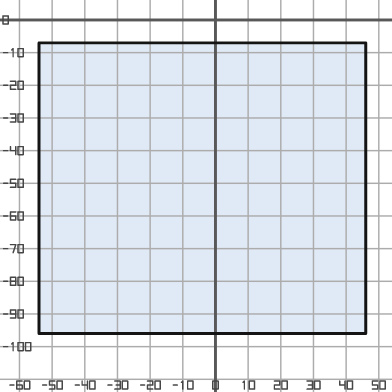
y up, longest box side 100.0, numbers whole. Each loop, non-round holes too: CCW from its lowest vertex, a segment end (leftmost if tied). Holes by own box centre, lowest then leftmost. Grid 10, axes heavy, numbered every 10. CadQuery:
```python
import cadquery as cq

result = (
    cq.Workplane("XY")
    .moveTo(-54.0, -96.0)
    .lineTo(46.0, -96.0)
    .lineTo(46.0, -7.0)
    .lineTo(-54.0, -7.0)
    .close()
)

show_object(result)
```